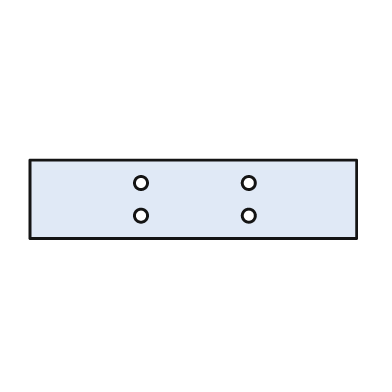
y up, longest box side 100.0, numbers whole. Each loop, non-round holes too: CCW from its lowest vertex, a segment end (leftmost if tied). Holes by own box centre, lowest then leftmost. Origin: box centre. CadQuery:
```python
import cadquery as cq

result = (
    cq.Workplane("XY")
    .moveTo(-50.0, -12.0)
    .lineTo(50.0, -12.0)
    .lineTo(50.0, 12.0)
    .lineTo(-50.0, 12.0)
    .close()
    .moveTo(-16.0, -5.0)
    .circle(2.0)
    .moveTo(17.0, -5.0)
    .circle(2.0)
    .moveTo(-16.0, 5.0)
    .circle(2.0)
    .moveTo(17.0, 5.0)
    .circle(2.0)
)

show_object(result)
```